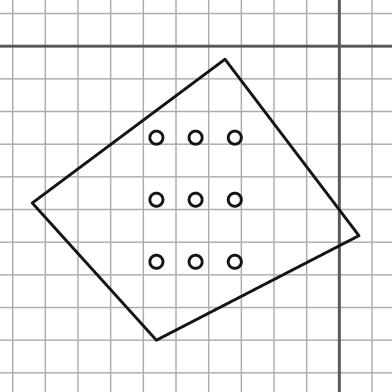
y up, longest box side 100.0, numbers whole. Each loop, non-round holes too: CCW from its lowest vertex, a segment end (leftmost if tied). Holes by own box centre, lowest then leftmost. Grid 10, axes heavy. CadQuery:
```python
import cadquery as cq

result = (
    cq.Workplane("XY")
    .moveTo(-56.0, -90.0)
    .lineTo(6.0, -58.0)
    .lineTo(-35.0, -4.0)
    .lineTo(-94.0, -48.0)
    .close()
    .moveTo(-56.0, -66.0)
    .circle(2.0)
    .moveTo(-44.0, -66.0)
    .circle(2.0)
    .moveTo(-32.0, -66.0)
    .circle(2.0)
    .moveTo(-56.0, -47.0)
    .circle(2.0)
    .moveTo(-44.0, -47.0)
    .circle(2.0)
    .moveTo(-32.0, -47.0)
    .circle(2.0)
    .moveTo(-56.0, -28.0)
    .circle(2.0)
    .moveTo(-44.0, -28.0)
    .circle(2.0)
    .moveTo(-32.0, -28.0)
    .circle(2.0)
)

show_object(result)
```